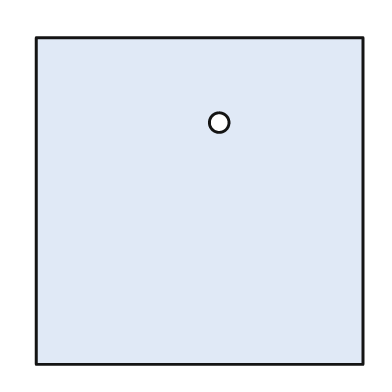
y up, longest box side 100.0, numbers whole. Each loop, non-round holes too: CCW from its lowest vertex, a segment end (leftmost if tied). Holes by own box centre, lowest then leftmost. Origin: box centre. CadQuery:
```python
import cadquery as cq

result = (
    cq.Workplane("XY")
    .moveTo(-50.0, -50.0)
    .lineTo(50.0, -50.0)
    .lineTo(50.0, 50.0)
    .lineTo(-50.0, 50.0)
    .close()
    .moveTo(6.0, 24.0)
    .circle(3.0)
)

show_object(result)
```